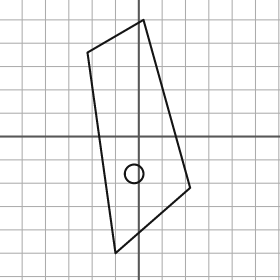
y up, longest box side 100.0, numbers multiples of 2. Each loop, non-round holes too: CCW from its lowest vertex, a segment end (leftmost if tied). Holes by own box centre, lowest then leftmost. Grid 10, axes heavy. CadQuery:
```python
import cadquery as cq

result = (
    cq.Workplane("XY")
    .moveTo(-10.0, -50.0)
    .lineTo(22.0, -22.0)
    .lineTo(2.0, 50.0)
    .lineTo(-22.0, 36.0)
    .close()
    .moveTo(-2.0, -16.0)
    .circle(4.0)
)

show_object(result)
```